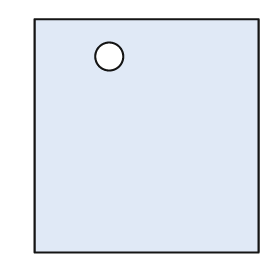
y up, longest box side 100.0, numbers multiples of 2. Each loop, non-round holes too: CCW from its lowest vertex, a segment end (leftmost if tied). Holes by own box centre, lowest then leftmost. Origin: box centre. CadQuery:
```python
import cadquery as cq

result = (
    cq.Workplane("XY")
    .moveTo(-48.0, -50.0)
    .lineTo(48.0, -50.0)
    .lineTo(48.0, 50.0)
    .lineTo(-48.0, 50.0)
    .close()
    .moveTo(-16.0, 34.0)
    .circle(6.0)
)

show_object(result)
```